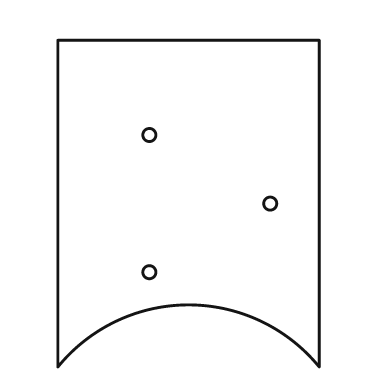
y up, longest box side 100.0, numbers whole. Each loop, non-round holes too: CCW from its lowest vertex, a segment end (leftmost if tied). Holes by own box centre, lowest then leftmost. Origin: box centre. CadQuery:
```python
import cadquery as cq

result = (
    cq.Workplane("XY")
    .moveTo(-40.0, -50.0)
    .threePointArc((0.0, -31.0), (40.0, -50.0))
    .lineTo(40.0, 50.0)
    .lineTo(-40.0, 50.0)
    .close()
    .moveTo(-12.0, -21.0)
    .circle(2.0)
    .moveTo(25.0, 0.0)
    .circle(2.0)
    .moveTo(-12.0, 21.0)
    .circle(2.0)
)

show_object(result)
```